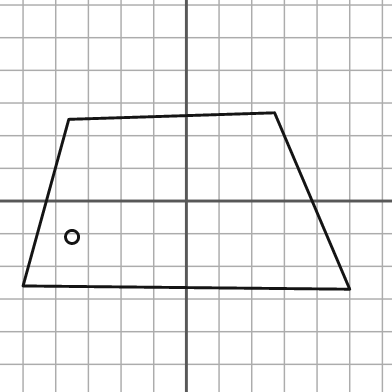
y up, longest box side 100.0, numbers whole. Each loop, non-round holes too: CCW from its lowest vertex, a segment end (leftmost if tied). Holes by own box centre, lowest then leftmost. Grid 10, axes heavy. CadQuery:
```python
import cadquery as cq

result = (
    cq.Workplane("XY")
    .moveTo(50.0, -27.0)
    .lineTo(27.0, 27.0)
    .lineTo(-36.0, 25.0)
    .lineTo(-50.0, -26.0)
    .close()
    .moveTo(-35.0, -11.0)
    .circle(2.0)
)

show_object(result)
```